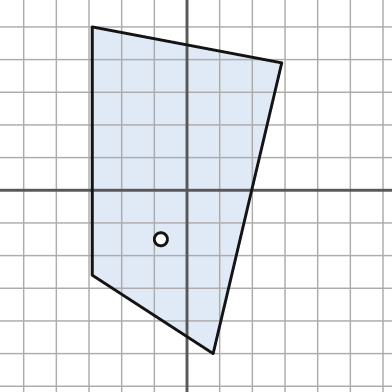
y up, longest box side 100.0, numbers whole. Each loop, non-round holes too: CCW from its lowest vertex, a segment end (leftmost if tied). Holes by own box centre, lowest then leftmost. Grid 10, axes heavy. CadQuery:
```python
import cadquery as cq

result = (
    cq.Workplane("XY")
    .moveTo(8.0, -50.0)
    .lineTo(29.0, 39.0)
    .lineTo(-29.0, 50.0)
    .lineTo(-29.0, -26.0)
    .close()
    .moveTo(-8.0, -15.0)
    .circle(2.0)
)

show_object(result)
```